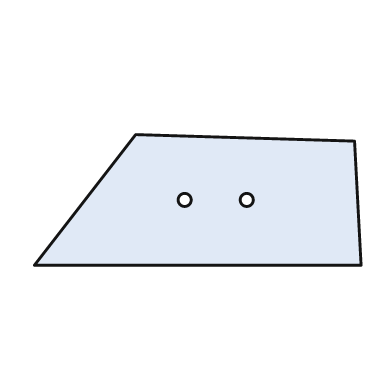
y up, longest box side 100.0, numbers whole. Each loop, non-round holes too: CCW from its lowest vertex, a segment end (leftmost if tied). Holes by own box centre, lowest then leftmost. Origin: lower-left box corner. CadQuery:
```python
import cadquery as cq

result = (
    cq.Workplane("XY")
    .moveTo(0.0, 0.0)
    .lineTo(100.0, 0.0)
    .lineTo(98.0, 38.0)
    .lineTo(31.0, 40.0)
    .close()
    .moveTo(46.0, 20.0)
    .circle(2.0)
    .moveTo(65.0, 20.0)
    .circle(2.0)
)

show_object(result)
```